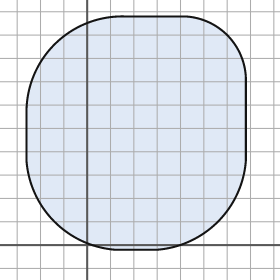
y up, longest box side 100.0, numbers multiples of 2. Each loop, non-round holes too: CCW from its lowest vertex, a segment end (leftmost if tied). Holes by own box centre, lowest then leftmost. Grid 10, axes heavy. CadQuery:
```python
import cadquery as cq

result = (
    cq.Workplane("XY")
    .moveTo(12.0, -2.0)
    .lineTo(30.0, -2.0)
    .threePointArc((56.0, 10.0), (68.0, 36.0))
    .lineTo(68.0, 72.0)
    .threePointArc((60.0, 90.0), (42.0, 98.0))
    .lineTo(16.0, 98.0)
    .threePointArc((-14.0, 86.0), (-26.0, 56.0))
    .lineTo(-26.0, 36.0)
    .threePointArc((-14.0, 10.0), (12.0, -2.0))
    .close()
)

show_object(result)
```